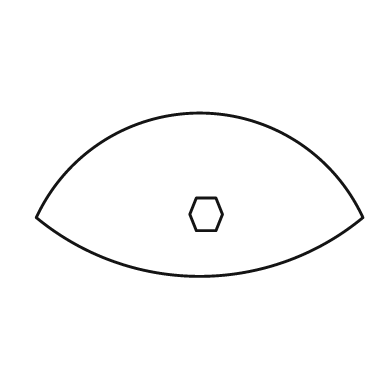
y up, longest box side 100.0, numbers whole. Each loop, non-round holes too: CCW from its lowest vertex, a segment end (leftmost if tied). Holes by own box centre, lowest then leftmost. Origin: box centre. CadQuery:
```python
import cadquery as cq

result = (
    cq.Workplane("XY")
    .moveTo(-50.0, -7.0)
    .threePointArc((0.0, -25.0), (50.0, -7.0))
    .threePointArc((0.0, 25.0), (-50.0, -7.0))
    .close()
    .moveTo(-1.0, -11.0)
    .lineTo(5.0, -11.0)
    .lineTo(7.0, -6.0)
    .lineTo(5.0, -1.0)
    .lineTo(-1.0, -1.0)
    .lineTo(-3.0, -6.0)
    .close()
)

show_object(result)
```